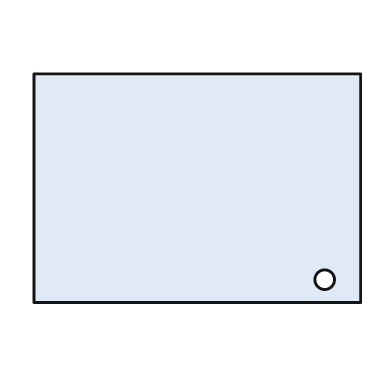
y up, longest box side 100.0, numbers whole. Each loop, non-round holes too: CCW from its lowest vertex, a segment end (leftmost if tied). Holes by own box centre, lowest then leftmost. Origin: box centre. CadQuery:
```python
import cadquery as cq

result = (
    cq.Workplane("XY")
    .moveTo(-50.0, -35.0)
    .lineTo(50.0, -35.0)
    .lineTo(50.0, 35.0)
    .lineTo(-50.0, 35.0)
    .close()
    .moveTo(39.0, -28.0)
    .circle(3.0)
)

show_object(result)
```